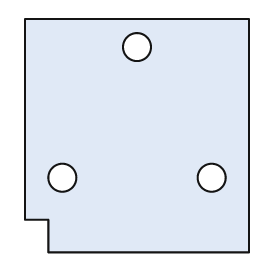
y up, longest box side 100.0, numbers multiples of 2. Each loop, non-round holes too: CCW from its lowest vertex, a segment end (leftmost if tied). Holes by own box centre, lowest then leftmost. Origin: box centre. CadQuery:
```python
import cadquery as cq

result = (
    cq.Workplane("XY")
    .moveTo(-38.0, -50.0)
    .lineTo(48.0, -50.0)
    .lineTo(48.0, 50.0)
    .lineTo(-48.0, 50.0)
    .lineTo(-48.0, -36.0)
    .lineTo(-38.0, -36.0)
    .close()
    .moveTo(-32.0, -18.0)
    .circle(6.0)
    .moveTo(32.0, -18.0)
    .circle(6.0)
    .moveTo(0.0, 38.0)
    .circle(6.0)
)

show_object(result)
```